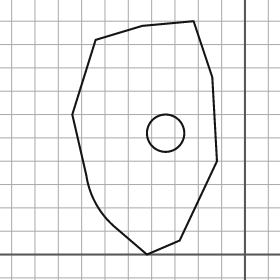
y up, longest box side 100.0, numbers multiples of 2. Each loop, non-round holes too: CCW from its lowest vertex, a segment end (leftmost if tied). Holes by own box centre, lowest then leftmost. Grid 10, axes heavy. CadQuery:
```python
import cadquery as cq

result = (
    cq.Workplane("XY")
    .moveTo(-42.0, 0.0)
    .lineTo(-28.0, 6.0)
    .lineTo(-12.0, 40.0)
    .lineTo(-14.0, 76.0)
    .lineTo(-22.0, 100.0)
    .lineTo(-44.0, 98.0)
    .lineTo(-64.0, 92.0)
    .lineTo(-74.0, 60.0)
    .lineTo(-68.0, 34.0)
    .threePointArc((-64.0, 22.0), (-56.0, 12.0))
    .close()
    .moveTo(-34.0, 52.0)
    .circle(8.0)
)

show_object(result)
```